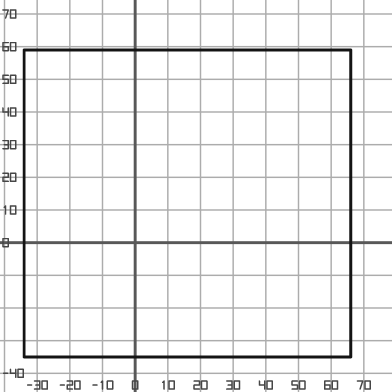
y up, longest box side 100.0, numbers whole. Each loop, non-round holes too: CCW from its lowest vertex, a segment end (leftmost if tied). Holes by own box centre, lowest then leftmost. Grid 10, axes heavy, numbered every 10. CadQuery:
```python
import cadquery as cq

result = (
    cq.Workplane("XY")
    .moveTo(-34.0, -35.0)
    .lineTo(66.0, -35.0)
    .lineTo(66.0, 59.0)
    .lineTo(-34.0, 59.0)
    .close()
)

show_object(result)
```